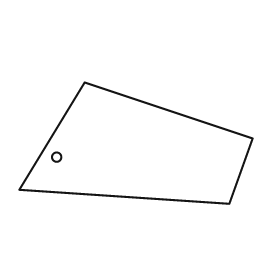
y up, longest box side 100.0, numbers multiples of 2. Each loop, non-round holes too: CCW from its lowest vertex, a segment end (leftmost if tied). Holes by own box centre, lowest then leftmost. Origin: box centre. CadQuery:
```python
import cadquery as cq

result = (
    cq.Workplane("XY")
    .moveTo(40.0, -26.0)
    .lineTo(50.0, 2.0)
    .lineTo(-22.0, 26.0)
    .lineTo(-50.0, -20.0)
    .close()
    .moveTo(-34.0, -6.0)
    .circle(2.0)
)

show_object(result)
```